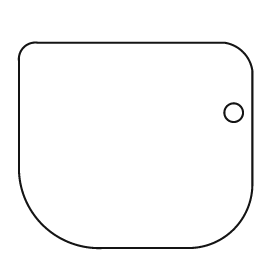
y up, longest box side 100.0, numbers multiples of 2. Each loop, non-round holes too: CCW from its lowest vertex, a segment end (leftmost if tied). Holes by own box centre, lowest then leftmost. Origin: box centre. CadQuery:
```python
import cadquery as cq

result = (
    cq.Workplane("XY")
    .moveTo(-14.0, -44.0)
    .lineTo(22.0, -44.0)
    .threePointArc((42.0, -36.0), (50.0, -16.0))
    .lineTo(50.0, 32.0)
    .threePointArc((46.0, 40.0), (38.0, 44.0))
    .lineTo(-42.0, 44.0)
    .threePointArc((-48.0, 42.0), (-50.0, 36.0))
    .lineTo(-50.0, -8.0)
    .threePointArc((-40.0, -34.0), (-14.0, -44.0))
    .close()
    .moveTo(42.0, 14.0)
    .circle(4.0)
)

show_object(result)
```